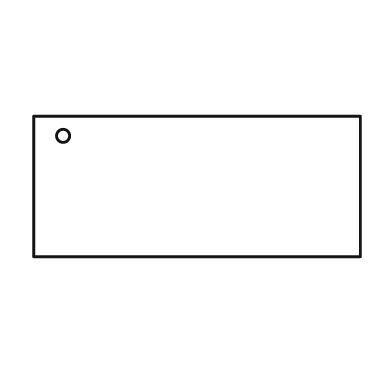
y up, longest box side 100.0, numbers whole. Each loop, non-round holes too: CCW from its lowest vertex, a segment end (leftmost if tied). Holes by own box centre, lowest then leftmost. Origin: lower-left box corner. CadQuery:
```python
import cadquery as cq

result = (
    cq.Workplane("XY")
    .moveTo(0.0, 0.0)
    .lineTo(100.0, 0.0)
    .lineTo(100.0, 43.0)
    .lineTo(0.0, 43.0)
    .close()
    .moveTo(9.0, 37.0)
    .circle(2.0)
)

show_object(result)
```